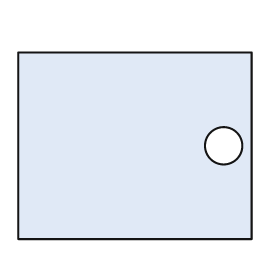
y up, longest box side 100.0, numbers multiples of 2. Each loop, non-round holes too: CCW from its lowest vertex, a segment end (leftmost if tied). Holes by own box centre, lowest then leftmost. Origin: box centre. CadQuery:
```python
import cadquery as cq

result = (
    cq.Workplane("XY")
    .moveTo(-50.0, -40.0)
    .lineTo(50.0, -40.0)
    .lineTo(50.0, 40.0)
    .lineTo(-50.0, 40.0)
    .close()
    .moveTo(38.0, 0.0)
    .circle(8.0)
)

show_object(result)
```